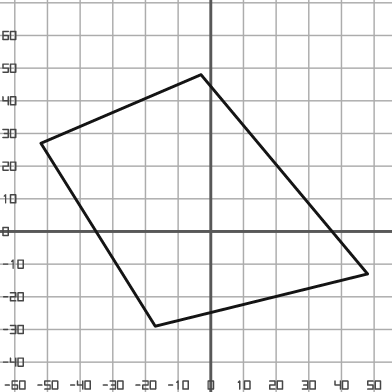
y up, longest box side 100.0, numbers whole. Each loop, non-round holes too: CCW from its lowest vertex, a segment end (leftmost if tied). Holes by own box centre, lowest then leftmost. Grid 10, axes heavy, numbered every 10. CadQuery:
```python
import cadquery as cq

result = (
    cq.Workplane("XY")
    .moveTo(-17.0, -29.0)
    .lineTo(48.0, -13.0)
    .lineTo(-3.0, 48.0)
    .lineTo(-52.0, 27.0)
    .close()
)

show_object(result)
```